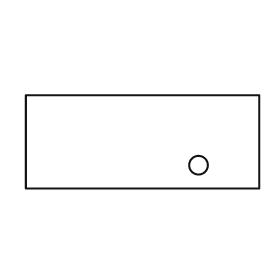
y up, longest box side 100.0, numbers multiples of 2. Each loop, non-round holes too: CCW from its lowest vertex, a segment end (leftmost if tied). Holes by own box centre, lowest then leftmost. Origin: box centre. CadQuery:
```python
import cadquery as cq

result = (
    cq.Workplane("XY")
    .moveTo(-50.0, -20.0)
    .lineTo(50.0, -20.0)
    .lineTo(50.0, 20.0)
    .lineTo(-50.0, 20.0)
    .close()
    .moveTo(24.0, -10.0)
    .circle(4.0)
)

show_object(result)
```